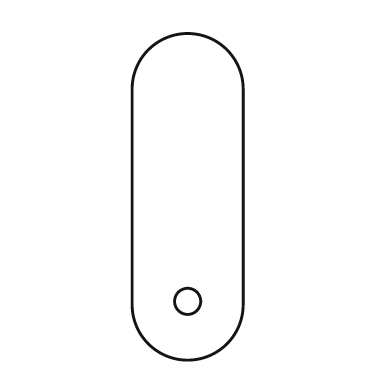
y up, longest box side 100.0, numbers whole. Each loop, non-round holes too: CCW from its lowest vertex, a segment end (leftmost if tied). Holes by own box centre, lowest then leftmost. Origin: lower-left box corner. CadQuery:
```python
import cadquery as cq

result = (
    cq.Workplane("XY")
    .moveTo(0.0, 17.0)
    .threePointArc((17.0, 0.0), (34.0, 17.0))
    .lineTo(34.0, 83.0)
    .threePointArc((17.0, 100.0), (0.0, 83.0))
    .close()
    .moveTo(17.0, 18.0)
    .circle(4.0)
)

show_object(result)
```